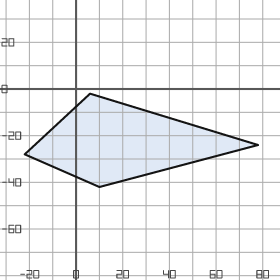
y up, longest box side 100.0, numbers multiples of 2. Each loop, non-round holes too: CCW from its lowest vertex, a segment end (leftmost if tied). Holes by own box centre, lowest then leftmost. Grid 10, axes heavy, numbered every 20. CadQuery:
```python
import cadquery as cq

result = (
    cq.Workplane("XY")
    .moveTo(10.0, -42.0)
    .lineTo(78.0, -24.0)
    .lineTo(6.0, -2.0)
    .lineTo(-22.0, -28.0)
    .close()
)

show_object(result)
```